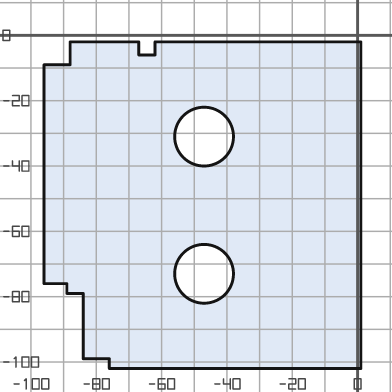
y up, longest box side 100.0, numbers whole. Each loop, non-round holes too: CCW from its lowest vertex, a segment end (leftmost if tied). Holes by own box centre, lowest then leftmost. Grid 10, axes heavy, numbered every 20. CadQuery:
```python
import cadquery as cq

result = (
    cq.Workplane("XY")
    .moveTo(-76.0, -102.0)
    .lineTo(1.0, -102.0)
    .lineTo(1.0, -2.0)
    .lineTo(-62.0, -2.0)
    .lineTo(-62.0, -6.0)
    .lineTo(-67.0, -6.0)
    .lineTo(-67.0, -2.0)
    .lineTo(-88.0, -2.0)
    .lineTo(-88.0, -9.0)
    .lineTo(-96.0, -9.0)
    .lineTo(-96.0, -76.0)
    .lineTo(-89.0, -76.0)
    .lineTo(-89.0, -79.0)
    .lineTo(-84.0, -79.0)
    .lineTo(-84.0, -99.0)
    .lineTo(-76.0, -99.0)
    .close()
    .moveTo(-47.0, -73.0)
    .circle(9.0)
    .moveTo(-47.0, -31.0)
    .circle(9.0)
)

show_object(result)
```